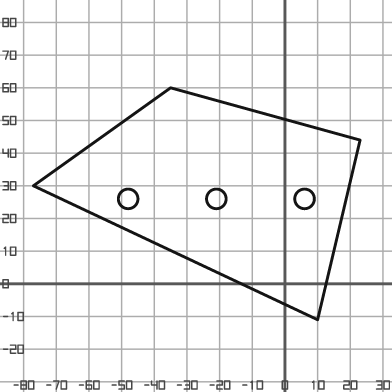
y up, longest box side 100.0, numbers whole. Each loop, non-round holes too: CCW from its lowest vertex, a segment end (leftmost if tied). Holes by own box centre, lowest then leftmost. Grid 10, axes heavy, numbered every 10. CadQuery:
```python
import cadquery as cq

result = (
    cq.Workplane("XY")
    .moveTo(10.0, -11.0)
    .lineTo(23.0, 44.0)
    .lineTo(-35.0, 60.0)
    .lineTo(-77.0, 30.0)
    .close()
    .moveTo(-48.0, 26.0)
    .circle(3.0)
    .moveTo(-21.0, 26.0)
    .circle(3.0)
    .moveTo(6.0, 26.0)
    .circle(3.0)
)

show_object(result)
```